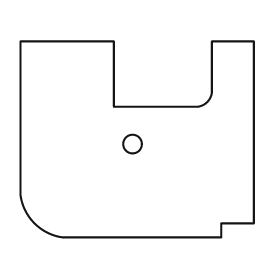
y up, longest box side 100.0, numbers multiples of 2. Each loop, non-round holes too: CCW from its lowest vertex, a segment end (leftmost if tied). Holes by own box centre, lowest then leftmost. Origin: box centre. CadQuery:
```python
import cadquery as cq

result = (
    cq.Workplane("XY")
    .moveTo(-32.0, -42.0)
    .lineTo(36.0, -42.0)
    .lineTo(36.0, -36.0)
    .lineTo(50.0, -36.0)
    .lineTo(50.0, 42.0)
    .lineTo(32.0, 42.0)
    .lineTo(32.0, 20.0)
    .threePointArc((30.0, 16.0), (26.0, 14.0))
    .lineTo(-10.0, 14.0)
    .lineTo(-10.0, 42.0)
    .lineTo(-50.0, 42.0)
    .lineTo(-50.0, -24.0)
    .threePointArc((-44.0, -36.0), (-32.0, -42.0))
    .close()
    .moveTo(-2.0, -2.0)
    .circle(4.0)
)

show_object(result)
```